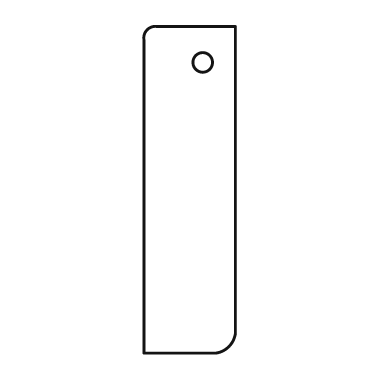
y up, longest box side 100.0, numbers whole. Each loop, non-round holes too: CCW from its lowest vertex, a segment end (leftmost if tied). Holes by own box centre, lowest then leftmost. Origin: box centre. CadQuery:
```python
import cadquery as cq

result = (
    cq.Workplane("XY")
    .moveTo(-14.0, -50.0)
    .lineTo(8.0, -50.0)
    .threePointArc((12.0, -48.0), (14.0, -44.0))
    .lineTo(14.0, 50.0)
    .lineTo(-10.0, 50.0)
    .threePointArc((-13.0, 49.0), (-14.0, 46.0))
    .close()
    .moveTo(4.0, 39.0)
    .circle(3.0)
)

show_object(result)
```